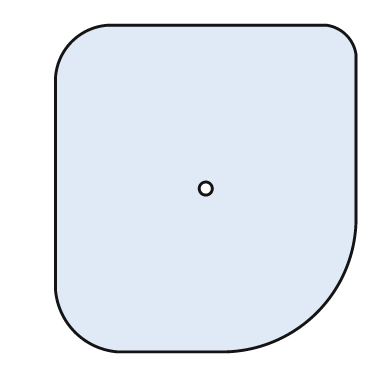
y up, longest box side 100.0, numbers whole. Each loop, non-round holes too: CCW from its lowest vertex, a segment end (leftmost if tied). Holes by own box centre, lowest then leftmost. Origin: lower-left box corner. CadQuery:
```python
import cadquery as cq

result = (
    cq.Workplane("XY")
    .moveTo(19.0, 0.0)
    .lineTo(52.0, 0.0)
    .threePointArc((80.0, 12.0), (92.0, 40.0))
    .lineTo(92.0, 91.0)
    .threePointArc((89.0, 97.0), (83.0, 100.0))
    .lineTo(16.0, 100.0)
    .threePointArc((5.0, 95.0), (0.0, 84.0))
    .lineTo(0.0, 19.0)
    .threePointArc((6.0, 6.0), (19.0, 0.0))
    .close()
    .moveTo(46.0, 50.0)
    .circle(2.0)
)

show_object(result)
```